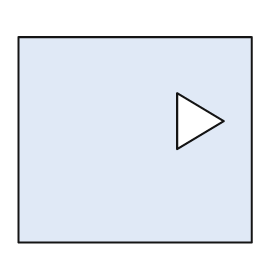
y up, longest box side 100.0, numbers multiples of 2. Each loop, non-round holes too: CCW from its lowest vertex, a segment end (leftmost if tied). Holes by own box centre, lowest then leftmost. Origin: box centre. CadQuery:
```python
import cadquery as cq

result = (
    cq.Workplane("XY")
    .moveTo(-50.0, -44.0)
    .lineTo(50.0, -44.0)
    .lineTo(50.0, 44.0)
    .lineTo(-50.0, 44.0)
    .close()
    .moveTo(18.0, -4.0)
    .lineTo(38.0, 8.0)
    .lineTo(18.0, 20.0)
    .close()
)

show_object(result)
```